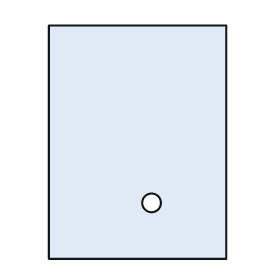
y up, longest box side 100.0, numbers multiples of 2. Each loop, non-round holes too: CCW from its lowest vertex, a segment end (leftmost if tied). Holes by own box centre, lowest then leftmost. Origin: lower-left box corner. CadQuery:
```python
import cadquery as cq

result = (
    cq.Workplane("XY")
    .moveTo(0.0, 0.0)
    .lineTo(76.0, 0.0)
    .lineTo(76.0, 100.0)
    .lineTo(0.0, 100.0)
    .close()
    .moveTo(44.0, 24.0)
    .circle(4.0)
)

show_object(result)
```